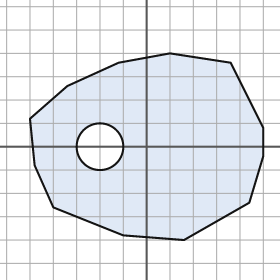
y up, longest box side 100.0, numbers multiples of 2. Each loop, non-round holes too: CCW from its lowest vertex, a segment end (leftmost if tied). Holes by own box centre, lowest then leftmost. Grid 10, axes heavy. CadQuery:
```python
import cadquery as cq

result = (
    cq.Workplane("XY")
    .moveTo(16.0, -40.0)
    .lineTo(44.0, -24.0)
    .lineTo(50.0, -4.0)
    .lineTo(50.0, 8.0)
    .lineTo(36.0, 36.0)
    .lineTo(10.0, 40.0)
    .lineTo(-12.0, 36.0)
    .lineTo(-34.0, 26.0)
    .lineTo(-50.0, 12.0)
    .lineTo(-48.0, -8.0)
    .lineTo(-40.0, -26.0)
    .lineTo(-10.0, -38.0)
    .close()
    .moveTo(-20.0, 0.0)
    .circle(10.0)
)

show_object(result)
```